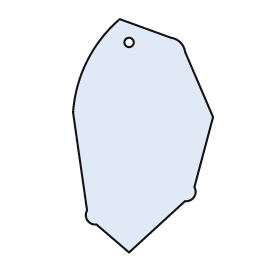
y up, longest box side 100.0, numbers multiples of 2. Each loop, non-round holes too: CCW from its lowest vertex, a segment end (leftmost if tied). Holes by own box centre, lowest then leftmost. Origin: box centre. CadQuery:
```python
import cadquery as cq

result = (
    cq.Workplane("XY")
    .moveTo(-6.0, -50.0)
    .lineTo(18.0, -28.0)
    .threePointArc((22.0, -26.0), (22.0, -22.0))
    .lineTo(30.0, 8.0)
    .lineTo(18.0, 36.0)
    .threePointArc((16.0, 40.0), (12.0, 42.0))
    .lineTo(-10.0, 50.0)
    .threePointArc((-24.0, 32.0), (-30.0, 10.0))
    .lineTo(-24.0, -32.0)
    .threePointArc((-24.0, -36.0), (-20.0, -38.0))
    .close()
    .moveTo(-6.0, 40.0)
    .circle(2.0)
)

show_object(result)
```